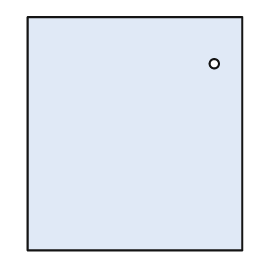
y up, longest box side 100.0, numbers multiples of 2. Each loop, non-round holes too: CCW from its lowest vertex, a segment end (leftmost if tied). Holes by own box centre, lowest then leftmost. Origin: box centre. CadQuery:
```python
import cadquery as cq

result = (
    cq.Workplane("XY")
    .moveTo(-46.0, -50.0)
    .lineTo(46.0, -50.0)
    .lineTo(46.0, 50.0)
    .lineTo(-46.0, 50.0)
    .close()
    .moveTo(34.0, 30.0)
    .circle(2.0)
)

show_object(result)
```